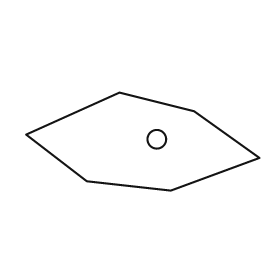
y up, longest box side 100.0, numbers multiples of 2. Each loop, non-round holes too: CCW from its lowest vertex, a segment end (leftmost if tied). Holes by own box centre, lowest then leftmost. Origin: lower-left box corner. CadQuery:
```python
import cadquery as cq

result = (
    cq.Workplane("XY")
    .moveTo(62.0, 0.0)
    .lineTo(100.0, 14.0)
    .lineTo(72.0, 34.0)
    .lineTo(40.0, 42.0)
    .lineTo(0.0, 24.0)
    .lineTo(26.0, 4.0)
    .close()
    .moveTo(56.0, 22.0)
    .circle(4.0)
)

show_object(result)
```